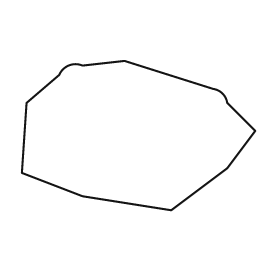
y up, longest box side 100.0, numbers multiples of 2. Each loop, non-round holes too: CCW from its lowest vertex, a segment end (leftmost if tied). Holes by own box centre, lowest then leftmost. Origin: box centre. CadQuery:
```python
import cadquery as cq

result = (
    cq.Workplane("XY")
    .moveTo(14.0, -32.0)
    .lineTo(38.0, -14.0)
    .lineTo(50.0, 2.0)
    .lineTo(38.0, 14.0)
    .threePointArc((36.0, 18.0), (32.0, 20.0))
    .lineTo(-6.0, 32.0)
    .lineTo(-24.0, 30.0)
    .threePointArc((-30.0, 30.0), (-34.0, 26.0))
    .lineTo(-48.0, 14.0)
    .lineTo(-50.0, -16.0)
    .lineTo(-24.0, -26.0)
    .close()
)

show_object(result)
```